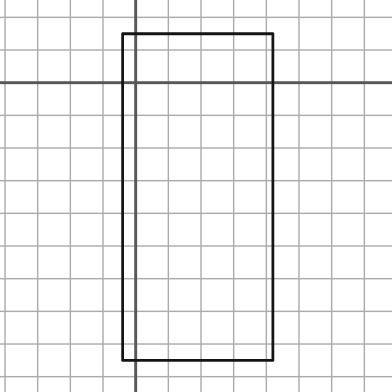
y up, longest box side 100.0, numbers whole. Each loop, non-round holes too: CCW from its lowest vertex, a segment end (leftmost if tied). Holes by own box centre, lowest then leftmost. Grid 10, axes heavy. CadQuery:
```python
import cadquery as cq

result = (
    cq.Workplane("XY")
    .moveTo(-4.0, -85.0)
    .lineTo(42.0, -85.0)
    .lineTo(42.0, 15.0)
    .lineTo(-4.0, 15.0)
    .close()
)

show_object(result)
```